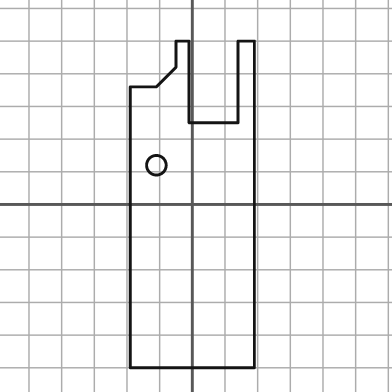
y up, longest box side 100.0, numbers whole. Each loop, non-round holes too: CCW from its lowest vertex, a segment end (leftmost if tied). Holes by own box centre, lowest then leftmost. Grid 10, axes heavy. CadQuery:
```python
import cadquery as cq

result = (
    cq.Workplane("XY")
    .moveTo(-19.0, -50.0)
    .lineTo(19.0, -50.0)
    .lineTo(19.0, 50.0)
    .lineTo(14.0, 50.0)
    .lineTo(14.0, 25.0)
    .lineTo(-1.0, 25.0)
    .lineTo(-1.0, 50.0)
    .lineTo(-5.0, 50.0)
    .lineTo(-5.0, 42.0)
    .lineTo(-11.0, 36.0)
    .lineTo(-19.0, 36.0)
    .close()
    .moveTo(-11.0, 12.0)
    .circle(3.0)
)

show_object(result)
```